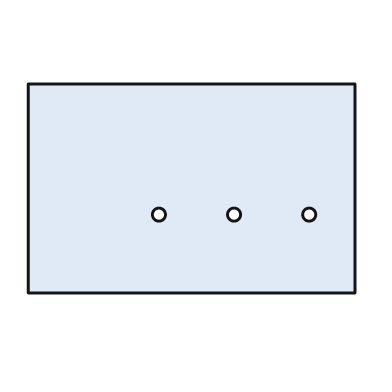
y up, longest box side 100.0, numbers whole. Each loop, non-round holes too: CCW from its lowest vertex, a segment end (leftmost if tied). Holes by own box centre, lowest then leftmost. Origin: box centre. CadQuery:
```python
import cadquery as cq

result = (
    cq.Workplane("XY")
    .moveTo(-50.0, -32.0)
    .lineTo(50.0, -32.0)
    .lineTo(50.0, 32.0)
    .lineTo(-50.0, 32.0)
    .close()
    .moveTo(-10.0, -8.0)
    .circle(2.0)
    .moveTo(13.0, -8.0)
    .circle(2.0)
    .moveTo(36.0, -8.0)
    .circle(2.0)
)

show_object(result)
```